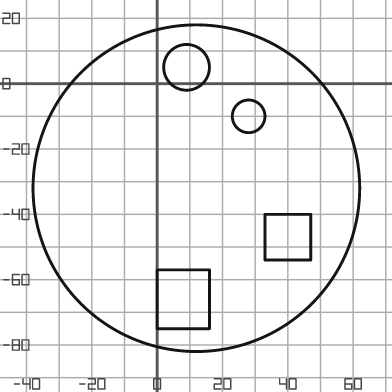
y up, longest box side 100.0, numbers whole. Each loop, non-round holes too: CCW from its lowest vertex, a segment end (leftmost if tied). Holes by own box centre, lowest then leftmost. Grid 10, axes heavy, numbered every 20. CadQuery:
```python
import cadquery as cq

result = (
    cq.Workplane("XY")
    .moveTo(12.0, -32.0)
    .circle(50.0)
    .moveTo(0.0, -75.0)
    .lineTo(16.0, -75.0)
    .lineTo(16.0, -57.0)
    .lineTo(0.0, -57.0)
    .close()
    .moveTo(33.0, -54.0)
    .lineTo(47.0, -54.0)
    .lineTo(47.0, -40.0)
    .lineTo(33.0, -40.0)
    .close()
    .moveTo(28.0, -10.0)
    .circle(5.0)
    .moveTo(9.0, 5.0)
    .circle(7.0)
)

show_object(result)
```